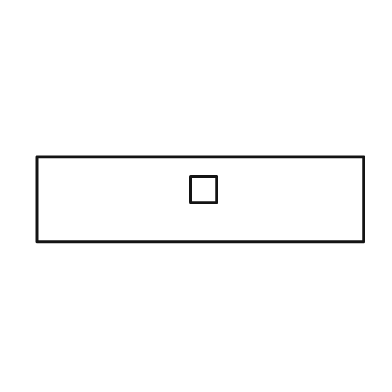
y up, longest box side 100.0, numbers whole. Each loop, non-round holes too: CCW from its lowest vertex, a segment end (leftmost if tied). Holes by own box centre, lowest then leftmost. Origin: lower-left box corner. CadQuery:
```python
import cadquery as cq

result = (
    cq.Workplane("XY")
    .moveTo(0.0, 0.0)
    .lineTo(100.0, 0.0)
    .lineTo(100.0, 26.0)
    .lineTo(0.0, 26.0)
    .close()
    .moveTo(47.0, 12.0)
    .lineTo(55.0, 12.0)
    .lineTo(55.0, 20.0)
    .lineTo(47.0, 20.0)
    .close()
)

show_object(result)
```